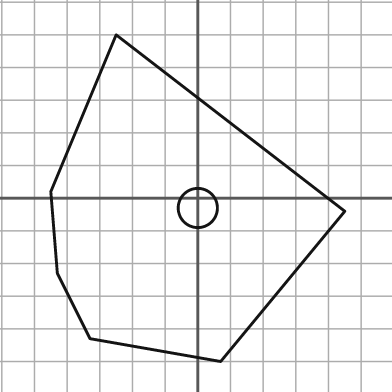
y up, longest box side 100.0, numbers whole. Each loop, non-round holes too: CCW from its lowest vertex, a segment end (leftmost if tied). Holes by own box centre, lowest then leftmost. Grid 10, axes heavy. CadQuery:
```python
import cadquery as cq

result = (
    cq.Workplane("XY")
    .moveTo(7.0, -50.0)
    .lineTo(45.0, -4.0)
    .lineTo(-25.0, 50.0)
    .lineTo(-45.0, 2.0)
    .lineTo(-43.0, -23.0)
    .lineTo(-33.0, -43.0)
    .close()
    .moveTo(0.0, -3.0)
    .circle(6.0)
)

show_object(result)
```